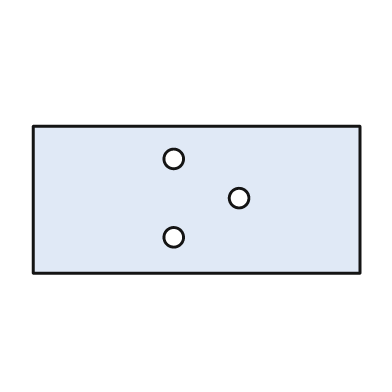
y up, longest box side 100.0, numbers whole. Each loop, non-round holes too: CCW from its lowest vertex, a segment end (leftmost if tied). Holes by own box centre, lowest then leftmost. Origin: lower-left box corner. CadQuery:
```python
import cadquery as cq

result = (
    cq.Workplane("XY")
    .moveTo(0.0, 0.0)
    .lineTo(100.0, 0.0)
    .lineTo(100.0, 45.0)
    .lineTo(0.0, 45.0)
    .close()
    .moveTo(43.0, 11.0)
    .circle(3.0)
    .moveTo(63.0, 23.0)
    .circle(3.0)
    .moveTo(43.0, 35.0)
    .circle(3.0)
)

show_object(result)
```